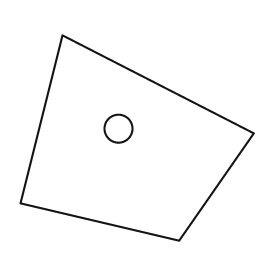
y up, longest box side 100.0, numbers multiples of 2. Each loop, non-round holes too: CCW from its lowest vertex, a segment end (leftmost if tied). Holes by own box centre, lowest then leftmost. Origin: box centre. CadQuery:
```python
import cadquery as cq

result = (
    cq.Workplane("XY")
    .moveTo(18.0, -44.0)
    .lineTo(50.0, 2.0)
    .lineTo(-32.0, 44.0)
    .lineTo(-50.0, -28.0)
    .close()
    .moveTo(-8.0, 4.0)
    .circle(6.0)
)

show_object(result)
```